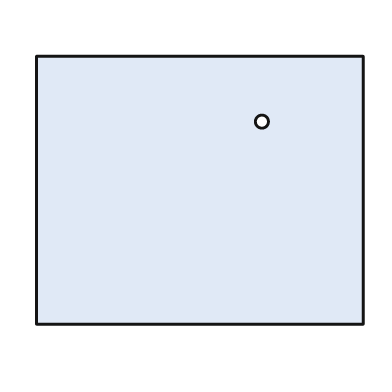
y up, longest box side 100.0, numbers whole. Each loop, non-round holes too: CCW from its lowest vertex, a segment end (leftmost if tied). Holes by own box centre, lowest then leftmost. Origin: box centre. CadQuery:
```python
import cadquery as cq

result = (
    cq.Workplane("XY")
    .moveTo(-50.0, -41.0)
    .lineTo(50.0, -41.0)
    .lineTo(50.0, 41.0)
    .lineTo(-50.0, 41.0)
    .close()
    .moveTo(19.0, 21.0)
    .circle(2.0)
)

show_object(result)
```